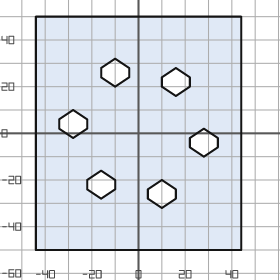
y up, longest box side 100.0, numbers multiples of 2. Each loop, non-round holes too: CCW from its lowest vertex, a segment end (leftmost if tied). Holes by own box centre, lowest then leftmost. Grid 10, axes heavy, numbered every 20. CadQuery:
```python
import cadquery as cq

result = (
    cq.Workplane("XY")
    .moveTo(-44.0, -50.0)
    .lineTo(44.0, -50.0)
    .lineTo(44.0, 50.0)
    .lineTo(-44.0, 50.0)
    .close()
    .moveTo(10.0, -32.0)
    .lineTo(16.0, -28.0)
    .lineTo(16.0, -24.0)
    .lineTo(10.0, -20.0)
    .lineTo(4.0, -24.0)
    .lineTo(4.0, -28.0)
    .close()
    .moveTo(-16.0, -28.0)
    .lineTo(-10.0, -24.0)
    .lineTo(-10.0, -20.0)
    .lineTo(-16.0, -16.0)
    .lineTo(-22.0, -20.0)
    .lineTo(-22.0, -24.0)
    .close()
    .moveTo(28.0, -10.0)
    .lineTo(34.0, -6.0)
    .lineTo(34.0, -2.0)
    .lineTo(28.0, 2.0)
    .lineTo(22.0, -2.0)
    .lineTo(22.0, -6.0)
    .close()
    .moveTo(-28.0, -2.0)
    .lineTo(-22.0, 2.0)
    .lineTo(-22.0, 6.0)
    .lineTo(-28.0, 10.0)
    .lineTo(-34.0, 6.0)
    .lineTo(-34.0, 2.0)
    .close()
    .moveTo(16.0, 16.0)
    .lineTo(22.0, 20.0)
    .lineTo(22.0, 24.0)
    .lineTo(16.0, 28.0)
    .lineTo(10.0, 24.0)
    .lineTo(10.0, 20.0)
    .close()
    .moveTo(-10.0, 20.0)
    .lineTo(-4.0, 24.0)
    .lineTo(-4.0, 28.0)
    .lineTo(-10.0, 32.0)
    .lineTo(-16.0, 28.0)
    .lineTo(-16.0, 24.0)
    .close()
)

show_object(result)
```